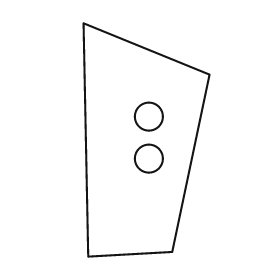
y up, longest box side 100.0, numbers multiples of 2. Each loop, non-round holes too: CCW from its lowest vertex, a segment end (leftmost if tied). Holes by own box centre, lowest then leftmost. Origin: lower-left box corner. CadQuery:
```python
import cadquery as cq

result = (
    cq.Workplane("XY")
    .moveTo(2.0, 0.0)
    .lineTo(38.0, 2.0)
    .lineTo(54.0, 78.0)
    .lineTo(0.0, 100.0)
    .close()
    .moveTo(28.0, 42.0)
    .circle(6.0)
    .moveTo(28.0, 60.0)
    .circle(6.0)
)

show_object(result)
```